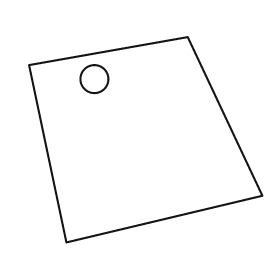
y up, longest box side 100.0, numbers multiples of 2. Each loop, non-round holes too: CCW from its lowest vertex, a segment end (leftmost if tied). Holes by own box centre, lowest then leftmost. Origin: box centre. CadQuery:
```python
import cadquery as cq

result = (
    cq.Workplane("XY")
    .moveTo(-34.0, -44.0)
    .lineTo(50.0, -24.0)
    .lineTo(18.0, 44.0)
    .lineTo(-50.0, 32.0)
    .close()
    .moveTo(-22.0, 26.0)
    .circle(6.0)
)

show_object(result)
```